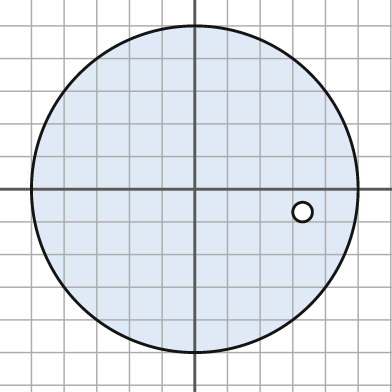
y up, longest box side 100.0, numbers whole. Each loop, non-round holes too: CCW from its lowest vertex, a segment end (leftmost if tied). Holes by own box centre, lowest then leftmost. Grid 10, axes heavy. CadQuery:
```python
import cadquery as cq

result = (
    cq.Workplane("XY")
    .moveTo(0.0, 0.0)
    .circle(50.0)
    .moveTo(33.0, -7.0)
    .circle(3.0)
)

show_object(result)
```